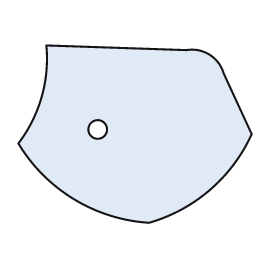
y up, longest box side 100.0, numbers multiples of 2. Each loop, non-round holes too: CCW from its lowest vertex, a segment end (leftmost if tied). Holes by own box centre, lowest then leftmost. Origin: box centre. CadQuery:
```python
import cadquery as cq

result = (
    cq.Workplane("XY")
    .moveTo(6.0, -38.0)
    .threePointArc((32.0, -24.0), (50.0, 0.0))
    .lineTo(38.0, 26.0)
    .threePointArc((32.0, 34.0), (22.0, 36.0))
    .lineTo(-38.0, 38.0)
    .threePointArc((-40.0, 16.0), (-50.0, -4.0))
    .threePointArc((-26.0, -28.0), (6.0, -38.0))
    .close()
    .moveTo(-16.0, 2.0)
    .circle(4.0)
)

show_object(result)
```